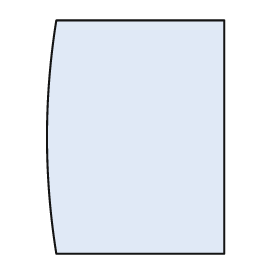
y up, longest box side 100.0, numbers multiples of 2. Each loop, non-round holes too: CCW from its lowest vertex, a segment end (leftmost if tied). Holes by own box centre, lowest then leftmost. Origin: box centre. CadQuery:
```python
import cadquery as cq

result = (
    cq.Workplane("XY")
    .moveTo(-34.0, -50.0)
    .lineTo(38.0, -50.0)
    .lineTo(38.0, 50.0)
    .lineTo(-34.0, 50.0)
    .threePointArc((-38.0, 0.0), (-34.0, -50.0))
    .close()
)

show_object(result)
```